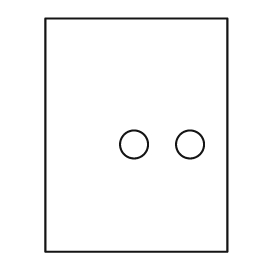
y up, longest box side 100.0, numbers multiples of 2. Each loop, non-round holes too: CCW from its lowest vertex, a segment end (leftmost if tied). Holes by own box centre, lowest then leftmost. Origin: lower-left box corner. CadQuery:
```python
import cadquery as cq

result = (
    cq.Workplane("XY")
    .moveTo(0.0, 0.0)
    .lineTo(78.0, 0.0)
    .lineTo(78.0, 100.0)
    .lineTo(0.0, 100.0)
    .close()
    .moveTo(38.0, 46.0)
    .circle(6.0)
    .moveTo(62.0, 46.0)
    .circle(6.0)
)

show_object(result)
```